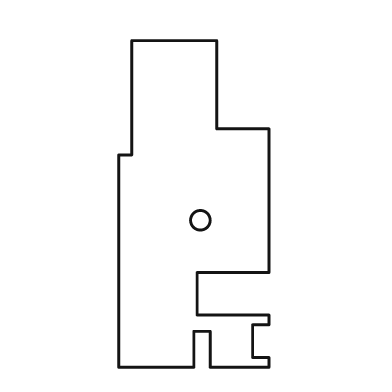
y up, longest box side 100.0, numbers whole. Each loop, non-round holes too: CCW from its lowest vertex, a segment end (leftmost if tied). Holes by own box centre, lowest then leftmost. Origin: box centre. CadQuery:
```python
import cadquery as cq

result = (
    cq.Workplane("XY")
    .moveTo(-23.0, -50.0)
    .lineTo(0.0, -50.0)
    .lineTo(0.0, -39.0)
    .lineTo(5.0, -39.0)
    .lineTo(5.0, -50.0)
    .lineTo(23.0, -50.0)
    .lineTo(23.0, -47.0)
    .lineTo(18.0, -47.0)
    .lineTo(18.0, -37.0)
    .lineTo(23.0, -37.0)
    .lineTo(23.0, -34.0)
    .lineTo(1.0, -34.0)
    .lineTo(1.0, -21.0)
    .lineTo(23.0, -21.0)
    .lineTo(23.0, 23.0)
    .lineTo(7.0, 23.0)
    .lineTo(7.0, 50.0)
    .lineTo(-19.0, 50.0)
    .lineTo(-19.0, 15.0)
    .lineTo(-23.0, 15.0)
    .close()
    .moveTo(2.0, -5.0)
    .circle(3.0)
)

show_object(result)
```